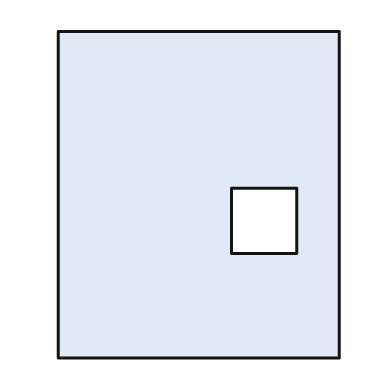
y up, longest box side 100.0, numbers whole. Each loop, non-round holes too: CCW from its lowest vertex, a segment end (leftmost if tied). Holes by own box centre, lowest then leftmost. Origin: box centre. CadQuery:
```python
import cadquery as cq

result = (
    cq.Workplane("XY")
    .moveTo(-43.0, -50.0)
    .lineTo(43.0, -50.0)
    .lineTo(43.0, 50.0)
    .lineTo(-43.0, 50.0)
    .close()
    .moveTo(10.0, -18.0)
    .lineTo(30.0, -18.0)
    .lineTo(30.0, 2.0)
    .lineTo(10.0, 2.0)
    .close()
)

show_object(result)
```